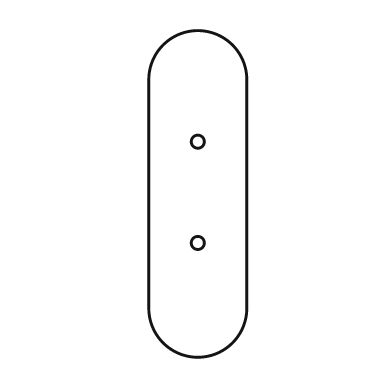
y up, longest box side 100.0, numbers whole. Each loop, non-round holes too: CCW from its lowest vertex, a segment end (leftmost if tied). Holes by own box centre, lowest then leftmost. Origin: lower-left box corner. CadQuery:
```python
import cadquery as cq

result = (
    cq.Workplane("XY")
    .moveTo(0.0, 15.0)
    .threePointArc((15.0, 0.0), (30.0, 15.0))
    .lineTo(30.0, 85.0)
    .threePointArc((15.0, 100.0), (0.0, 85.0))
    .close()
    .moveTo(15.0, 35.0)
    .circle(2.0)
    .moveTo(15.0, 66.0)
    .circle(2.0)
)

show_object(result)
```